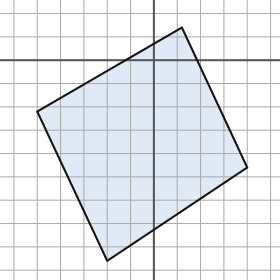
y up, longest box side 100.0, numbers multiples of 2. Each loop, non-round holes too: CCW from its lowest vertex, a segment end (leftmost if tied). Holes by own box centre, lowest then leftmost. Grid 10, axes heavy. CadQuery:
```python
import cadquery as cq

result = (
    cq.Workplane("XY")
    .moveTo(-20.0, -86.0)
    .lineTo(40.0, -46.0)
    .lineTo(12.0, 14.0)
    .lineTo(-50.0, -22.0)
    .close()
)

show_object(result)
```